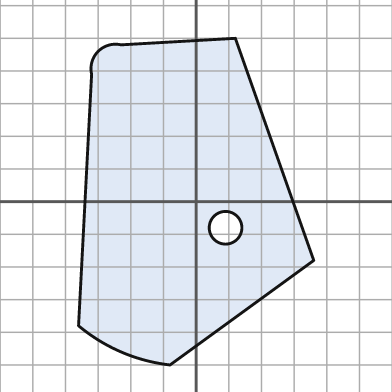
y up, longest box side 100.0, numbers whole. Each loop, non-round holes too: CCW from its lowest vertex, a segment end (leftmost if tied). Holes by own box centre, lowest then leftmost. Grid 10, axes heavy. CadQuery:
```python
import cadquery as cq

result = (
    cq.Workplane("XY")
    .moveTo(-8.0, -50.0)
    .lineTo(36.0, -18.0)
    .lineTo(12.0, 50.0)
    .lineTo(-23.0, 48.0)
    .threePointArc((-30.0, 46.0), (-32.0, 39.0))
    .lineTo(-36.0, -38.0)
    .threePointArc((-23.0, -46.0), (-8.0, -50.0))
    .close()
    .moveTo(9.0, -8.0)
    .circle(5.0)
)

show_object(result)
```